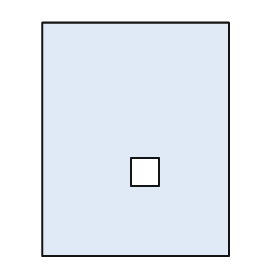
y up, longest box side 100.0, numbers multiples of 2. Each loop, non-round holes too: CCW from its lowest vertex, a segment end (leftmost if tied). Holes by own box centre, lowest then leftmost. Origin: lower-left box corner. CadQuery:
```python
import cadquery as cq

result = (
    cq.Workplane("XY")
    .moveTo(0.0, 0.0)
    .lineTo(80.0, 0.0)
    .lineTo(80.0, 100.0)
    .lineTo(0.0, 100.0)
    .close()
    .moveTo(38.0, 30.0)
    .lineTo(50.0, 30.0)
    .lineTo(50.0, 42.0)
    .lineTo(38.0, 42.0)
    .close()
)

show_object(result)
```